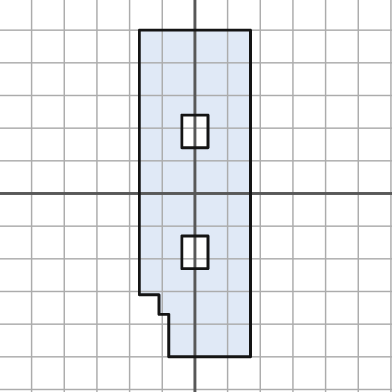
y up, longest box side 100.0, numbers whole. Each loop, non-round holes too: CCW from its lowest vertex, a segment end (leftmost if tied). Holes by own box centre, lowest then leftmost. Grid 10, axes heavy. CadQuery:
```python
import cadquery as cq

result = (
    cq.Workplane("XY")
    .moveTo(-8.0, -50.0)
    .lineTo(17.0, -50.0)
    .lineTo(17.0, 50.0)
    .lineTo(-17.0, 50.0)
    .lineTo(-17.0, -31.0)
    .lineTo(-11.0, -31.0)
    .lineTo(-11.0, -37.0)
    .lineTo(-8.0, -37.0)
    .close()
    .moveTo(-4.0, -23.0)
    .lineTo(4.0, -23.0)
    .lineTo(4.0, -13.0)
    .lineTo(-4.0, -13.0)
    .close()
    .moveTo(-4.0, 14.0)
    .lineTo(4.0, 14.0)
    .lineTo(4.0, 24.0)
    .lineTo(-4.0, 24.0)
    .close()
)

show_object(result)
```